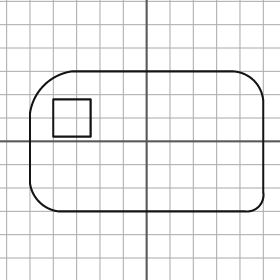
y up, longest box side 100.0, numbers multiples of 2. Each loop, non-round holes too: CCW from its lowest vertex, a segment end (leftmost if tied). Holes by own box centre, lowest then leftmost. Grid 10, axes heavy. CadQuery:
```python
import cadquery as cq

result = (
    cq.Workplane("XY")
    .moveTo(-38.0, -30.0)
    .lineTo(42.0, -30.0)
    .threePointArc((48.0, -28.0), (50.0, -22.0))
    .lineTo(50.0, 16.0)
    .threePointArc((46.0, 26.0), (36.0, 30.0))
    .lineTo(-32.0, 30.0)
    .threePointArc((-44.0, 24.0), (-50.0, 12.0))
    .lineTo(-50.0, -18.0)
    .threePointArc((-46.0, -26.0), (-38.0, -30.0))
    .close()
    .moveTo(-40.0, 2.0)
    .lineTo(-24.0, 2.0)
    .lineTo(-24.0, 18.0)
    .lineTo(-40.0, 18.0)
    .close()
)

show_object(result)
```